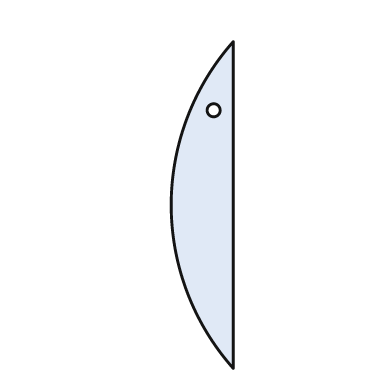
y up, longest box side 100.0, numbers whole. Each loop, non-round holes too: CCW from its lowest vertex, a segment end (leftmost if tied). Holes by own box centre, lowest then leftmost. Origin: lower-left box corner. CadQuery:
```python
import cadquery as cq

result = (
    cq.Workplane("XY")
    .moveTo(19.0, 0.0)
    .lineTo(19.0, 100.0)
    .threePointArc((0.0, 50.0), (19.0, 0.0))
    .close()
    .moveTo(13.0, 79.0)
    .circle(2.0)
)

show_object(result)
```